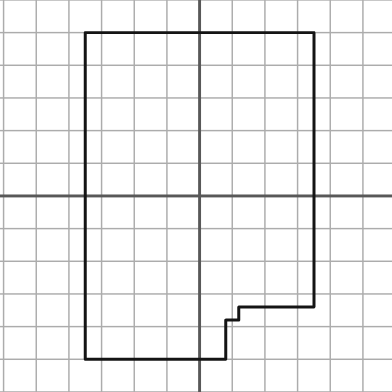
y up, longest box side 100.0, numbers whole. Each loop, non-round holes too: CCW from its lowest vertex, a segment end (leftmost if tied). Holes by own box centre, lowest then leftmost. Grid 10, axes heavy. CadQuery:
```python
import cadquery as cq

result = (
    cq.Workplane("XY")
    .moveTo(-35.0, -50.0)
    .lineTo(8.0, -50.0)
    .lineTo(8.0, -38.0)
    .lineTo(12.0, -38.0)
    .lineTo(12.0, -34.0)
    .lineTo(35.0, -34.0)
    .lineTo(35.0, 50.0)
    .lineTo(-35.0, 50.0)
    .close()
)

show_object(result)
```